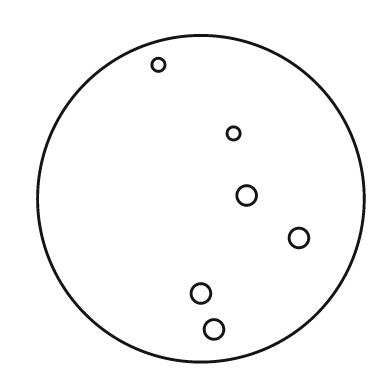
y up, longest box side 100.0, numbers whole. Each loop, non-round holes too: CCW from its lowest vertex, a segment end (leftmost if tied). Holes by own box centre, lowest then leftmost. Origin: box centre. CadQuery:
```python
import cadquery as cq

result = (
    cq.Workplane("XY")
    .moveTo(0.0, 0.0)
    .circle(50.0)
    .moveTo(4.0, -40.0)
    .circle(3.0)
    .moveTo(0.0, -29.0)
    .circle(3.0)
    .moveTo(30.0, -12.0)
    .circle(3.0)
    .moveTo(14.0, 1.0)
    .circle(3.0)
    .moveTo(10.0, 20.0)
    .circle(2.0)
    .moveTo(-13.0, 41.0)
    .circle(2.0)
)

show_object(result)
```